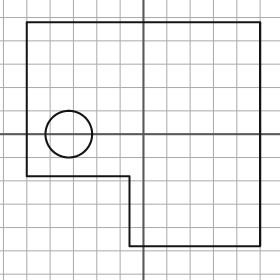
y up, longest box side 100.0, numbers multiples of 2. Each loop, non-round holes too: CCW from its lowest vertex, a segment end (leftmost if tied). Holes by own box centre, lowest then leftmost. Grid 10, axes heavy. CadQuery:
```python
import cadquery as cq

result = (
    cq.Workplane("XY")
    .moveTo(-6.0, -48.0)
    .lineTo(50.0, -48.0)
    .lineTo(50.0, 48.0)
    .lineTo(-50.0, 48.0)
    .lineTo(-50.0, -18.0)
    .lineTo(-6.0, -18.0)
    .close()
    .moveTo(-32.0, 0.0)
    .circle(10.0)
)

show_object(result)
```